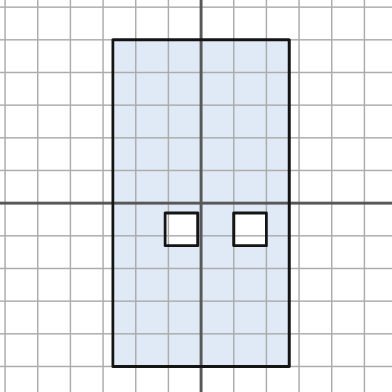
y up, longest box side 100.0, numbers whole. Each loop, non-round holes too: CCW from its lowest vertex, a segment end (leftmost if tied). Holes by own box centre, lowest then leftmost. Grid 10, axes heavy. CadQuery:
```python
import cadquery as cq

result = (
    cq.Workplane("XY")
    .moveTo(-27.0, -50.0)
    .lineTo(27.0, -50.0)
    .lineTo(27.0, 50.0)
    .lineTo(-27.0, 50.0)
    .close()
    .moveTo(-11.0, -13.0)
    .lineTo(-1.0, -13.0)
    .lineTo(-1.0, -3.0)
    .lineTo(-11.0, -3.0)
    .close()
    .moveTo(10.0, -13.0)
    .lineTo(20.0, -13.0)
    .lineTo(20.0, -3.0)
    .lineTo(10.0, -3.0)
    .close()
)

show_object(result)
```